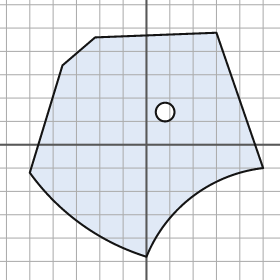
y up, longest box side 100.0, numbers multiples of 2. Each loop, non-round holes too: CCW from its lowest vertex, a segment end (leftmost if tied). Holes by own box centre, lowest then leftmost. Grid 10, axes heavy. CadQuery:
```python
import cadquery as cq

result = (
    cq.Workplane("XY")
    .moveTo(0.0, -48.0)
    .threePointArc((20.0, -22.0), (50.0, -10.0))
    .lineTo(30.0, 48.0)
    .lineTo(-22.0, 46.0)
    .lineTo(-36.0, 34.0)
    .lineTo(-50.0, -12.0)
    .threePointArc((-28.0, -34.0), (0.0, -48.0))
    .close()
    .moveTo(8.0, 14.0)
    .circle(4.0)
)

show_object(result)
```